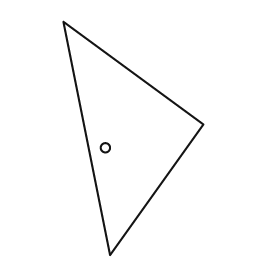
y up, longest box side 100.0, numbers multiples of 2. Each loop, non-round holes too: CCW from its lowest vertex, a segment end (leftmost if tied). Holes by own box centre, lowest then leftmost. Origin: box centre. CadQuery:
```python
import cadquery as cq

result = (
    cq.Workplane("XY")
    .moveTo(-10.0, -50.0)
    .lineTo(30.0, 6.0)
    .lineTo(-30.0, 50.0)
    .close()
    .moveTo(-12.0, -4.0)
    .circle(2.0)
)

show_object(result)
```